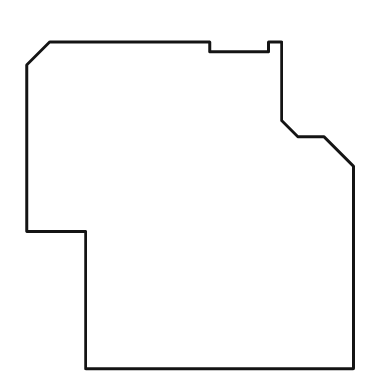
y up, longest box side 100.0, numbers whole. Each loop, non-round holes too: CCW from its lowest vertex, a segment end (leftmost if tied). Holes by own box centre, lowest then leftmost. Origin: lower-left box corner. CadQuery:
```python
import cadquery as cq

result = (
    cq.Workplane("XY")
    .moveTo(18.0, 0.0)
    .lineTo(100.0, 0.0)
    .lineTo(100.0, 62.0)
    .lineTo(91.0, 71.0)
    .lineTo(83.0, 71.0)
    .lineTo(78.0, 76.0)
    .lineTo(78.0, 100.0)
    .lineTo(74.0, 100.0)
    .lineTo(74.0, 97.0)
    .lineTo(56.0, 97.0)
    .lineTo(56.0, 100.0)
    .lineTo(7.0, 100.0)
    .lineTo(0.0, 93.0)
    .lineTo(0.0, 42.0)
    .lineTo(18.0, 42.0)
    .close()
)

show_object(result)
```